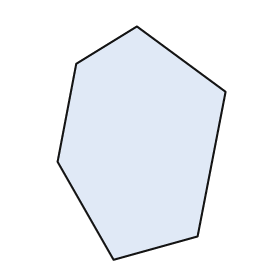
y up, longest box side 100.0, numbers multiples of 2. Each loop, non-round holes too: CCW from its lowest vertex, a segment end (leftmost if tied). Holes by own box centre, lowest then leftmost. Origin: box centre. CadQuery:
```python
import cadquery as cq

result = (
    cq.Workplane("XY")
    .moveTo(-12.0, -50.0)
    .lineTo(24.0, -40.0)
    .lineTo(36.0, 22.0)
    .lineTo(-2.0, 50.0)
    .lineTo(-28.0, 34.0)
    .lineTo(-36.0, -8.0)
    .close()
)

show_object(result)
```